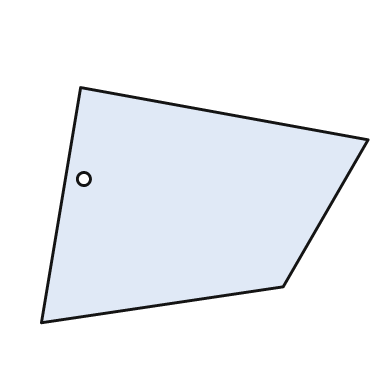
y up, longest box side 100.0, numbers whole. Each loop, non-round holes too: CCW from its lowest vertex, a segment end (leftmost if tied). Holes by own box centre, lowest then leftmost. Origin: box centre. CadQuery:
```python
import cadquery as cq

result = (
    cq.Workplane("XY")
    .moveTo(-50.0, -36.0)
    .lineTo(24.0, -25.0)
    .lineTo(50.0, 20.0)
    .lineTo(-38.0, 36.0)
    .close()
    .moveTo(-37.0, 8.0)
    .circle(2.0)
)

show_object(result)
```